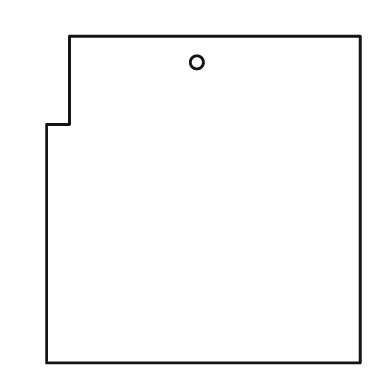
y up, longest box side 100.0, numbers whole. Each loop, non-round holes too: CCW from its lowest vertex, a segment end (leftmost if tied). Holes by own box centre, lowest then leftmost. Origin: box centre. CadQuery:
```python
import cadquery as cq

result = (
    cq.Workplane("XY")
    .moveTo(-48.0, -50.0)
    .lineTo(48.0, -50.0)
    .lineTo(48.0, 50.0)
    .lineTo(-41.0, 50.0)
    .lineTo(-41.0, 23.0)
    .lineTo(-48.0, 23.0)
    .close()
    .moveTo(-2.0, 42.0)
    .circle(2.0)
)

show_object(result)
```